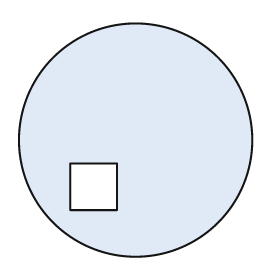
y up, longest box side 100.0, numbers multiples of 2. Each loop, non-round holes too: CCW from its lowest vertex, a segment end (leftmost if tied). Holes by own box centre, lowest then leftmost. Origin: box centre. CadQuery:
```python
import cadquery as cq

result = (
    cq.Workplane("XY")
    .moveTo(0.0, 0.0)
    .circle(50.0)
    .moveTo(-28.0, -30.0)
    .lineTo(-8.0, -30.0)
    .lineTo(-8.0, -10.0)
    .lineTo(-28.0, -10.0)
    .close()
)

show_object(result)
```